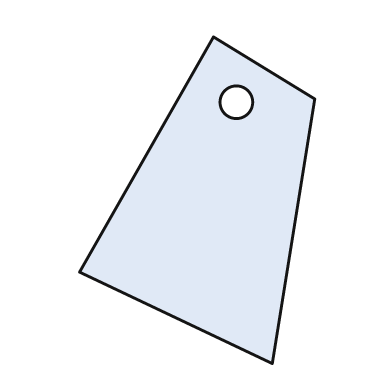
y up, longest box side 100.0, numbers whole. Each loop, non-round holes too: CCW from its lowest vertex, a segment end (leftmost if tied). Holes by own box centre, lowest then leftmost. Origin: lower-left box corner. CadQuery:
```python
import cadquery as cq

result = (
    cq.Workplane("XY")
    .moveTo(59.0, 0.0)
    .lineTo(72.0, 81.0)
    .lineTo(41.0, 100.0)
    .lineTo(0.0, 28.0)
    .close()
    .moveTo(48.0, 80.0)
    .circle(5.0)
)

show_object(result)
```